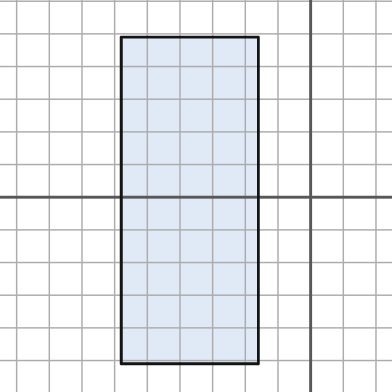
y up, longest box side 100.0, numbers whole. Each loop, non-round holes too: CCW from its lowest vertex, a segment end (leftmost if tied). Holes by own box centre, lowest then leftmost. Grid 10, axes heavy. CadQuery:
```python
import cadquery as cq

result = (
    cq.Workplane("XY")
    .moveTo(-58.0, -51.0)
    .lineTo(-16.0, -51.0)
    .lineTo(-16.0, 49.0)
    .lineTo(-58.0, 49.0)
    .close()
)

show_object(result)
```